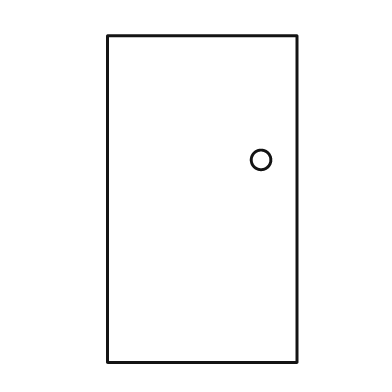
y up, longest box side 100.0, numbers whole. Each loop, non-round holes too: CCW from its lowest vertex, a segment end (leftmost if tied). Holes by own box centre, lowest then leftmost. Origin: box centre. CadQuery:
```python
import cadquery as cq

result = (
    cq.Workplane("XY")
    .moveTo(-29.0, -50.0)
    .lineTo(29.0, -50.0)
    .lineTo(29.0, 50.0)
    .lineTo(-29.0, 50.0)
    .close()
    .moveTo(18.0, 12.0)
    .circle(3.0)
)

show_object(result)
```